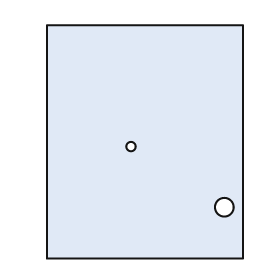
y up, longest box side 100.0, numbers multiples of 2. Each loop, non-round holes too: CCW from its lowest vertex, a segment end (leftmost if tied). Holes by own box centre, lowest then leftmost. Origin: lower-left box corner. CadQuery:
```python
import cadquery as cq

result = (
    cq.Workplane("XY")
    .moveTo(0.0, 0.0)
    .lineTo(84.0, 0.0)
    .lineTo(84.0, 100.0)
    .lineTo(0.0, 100.0)
    .close()
    .moveTo(76.0, 22.0)
    .circle(4.0)
    .moveTo(36.0, 48.0)
    .circle(2.0)
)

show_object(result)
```